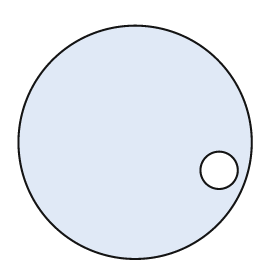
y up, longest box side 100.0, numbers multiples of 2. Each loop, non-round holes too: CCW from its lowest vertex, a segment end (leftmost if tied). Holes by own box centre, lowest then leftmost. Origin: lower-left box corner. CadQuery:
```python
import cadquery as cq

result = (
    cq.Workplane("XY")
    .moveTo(50.0, 50.0)
    .circle(50.0)
    .moveTo(86.0, 38.0)
    .circle(8.0)
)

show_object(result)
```